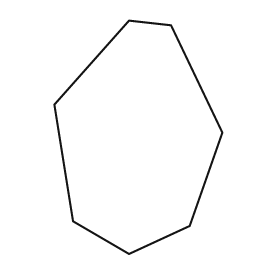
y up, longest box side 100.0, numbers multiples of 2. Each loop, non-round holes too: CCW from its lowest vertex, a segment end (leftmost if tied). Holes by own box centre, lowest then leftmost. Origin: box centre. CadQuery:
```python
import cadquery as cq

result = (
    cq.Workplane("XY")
    .moveTo(-4.0, -50.0)
    .lineTo(22.0, -38.0)
    .lineTo(36.0, 2.0)
    .lineTo(14.0, 48.0)
    .lineTo(-4.0, 50.0)
    .lineTo(-36.0, 14.0)
    .lineTo(-28.0, -36.0)
    .close()
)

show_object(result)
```